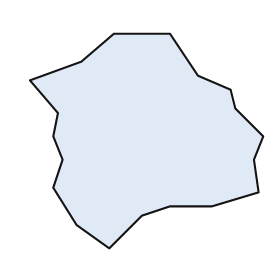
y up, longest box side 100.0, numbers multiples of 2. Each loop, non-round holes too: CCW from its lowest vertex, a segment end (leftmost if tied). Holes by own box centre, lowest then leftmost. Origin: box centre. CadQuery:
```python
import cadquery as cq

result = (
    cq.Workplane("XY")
    .moveTo(-16.0, -46.0)
    .lineTo(-2.0, -32.0)
    .lineTo(10.0, -28.0)
    .lineTo(28.0, -28.0)
    .lineTo(48.0, -22.0)
    .lineTo(46.0, -8.0)
    .lineTo(50.0, 2.0)
    .lineTo(38.0, 14.0)
    .lineTo(36.0, 22.0)
    .lineTo(22.0, 28.0)
    .lineTo(10.0, 46.0)
    .lineTo(-14.0, 46.0)
    .lineTo(-28.0, 34.0)
    .lineTo(-50.0, 26.0)
    .lineTo(-38.0, 12.0)
    .lineTo(-40.0, 2.0)
    .lineTo(-36.0, -8.0)
    .lineTo(-40.0, -20.0)
    .lineTo(-30.0, -36.0)
    .close()
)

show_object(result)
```